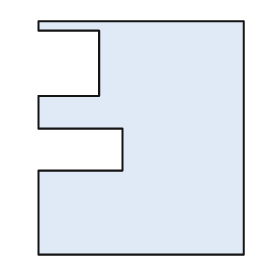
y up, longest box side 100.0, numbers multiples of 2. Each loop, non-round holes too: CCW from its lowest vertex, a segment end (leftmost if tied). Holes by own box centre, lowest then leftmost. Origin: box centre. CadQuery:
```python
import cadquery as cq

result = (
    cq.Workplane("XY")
    .moveTo(-44.0, -50.0)
    .lineTo(44.0, -50.0)
    .lineTo(44.0, 50.0)
    .lineTo(-44.0, 50.0)
    .lineTo(-44.0, 46.0)
    .lineTo(-18.0, 46.0)
    .lineTo(-18.0, 18.0)
    .lineTo(-44.0, 18.0)
    .lineTo(-44.0, 4.0)
    .lineTo(-8.0, 4.0)
    .lineTo(-8.0, -14.0)
    .lineTo(-44.0, -14.0)
    .close()
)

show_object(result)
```